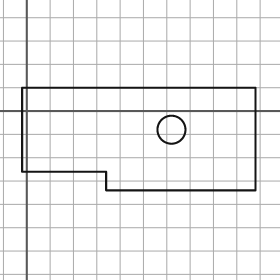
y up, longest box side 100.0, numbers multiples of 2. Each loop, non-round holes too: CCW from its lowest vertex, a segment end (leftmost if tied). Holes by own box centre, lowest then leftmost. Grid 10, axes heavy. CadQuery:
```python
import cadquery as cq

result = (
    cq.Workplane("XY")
    .moveTo(34.0, -34.0)
    .lineTo(98.0, -34.0)
    .lineTo(98.0, 10.0)
    .lineTo(-2.0, 10.0)
    .lineTo(-2.0, -26.0)
    .lineTo(34.0, -26.0)
    .close()
    .moveTo(62.0, -8.0)
    .circle(6.0)
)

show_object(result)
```